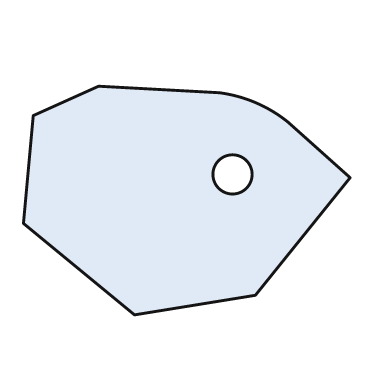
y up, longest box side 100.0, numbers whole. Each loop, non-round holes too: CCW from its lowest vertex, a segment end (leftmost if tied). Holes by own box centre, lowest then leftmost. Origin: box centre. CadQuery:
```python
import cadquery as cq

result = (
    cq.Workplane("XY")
    .moveTo(-16.0, -35.0)
    .lineTo(21.0, -29.0)
    .lineTo(50.0, 7.0)
    .lineTo(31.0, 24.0)
    .threePointArc((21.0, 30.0), (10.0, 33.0))
    .lineTo(-27.0, 35.0)
    .lineTo(-47.0, 26.0)
    .lineTo(-50.0, -7.0)
    .close()
    .moveTo(14.0, 8.0)
    .circle(6.0)
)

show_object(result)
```